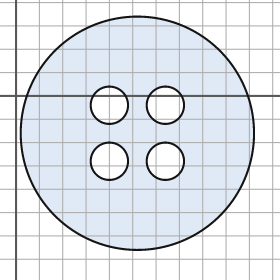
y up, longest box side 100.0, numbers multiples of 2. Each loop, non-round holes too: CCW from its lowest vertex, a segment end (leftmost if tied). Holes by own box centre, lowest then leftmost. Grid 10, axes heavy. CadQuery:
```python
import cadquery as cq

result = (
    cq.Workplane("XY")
    .moveTo(52.0, -16.0)
    .circle(50.0)
    .moveTo(40.0, -28.0)
    .circle(8.0)
    .moveTo(64.0, -28.0)
    .circle(8.0)
    .moveTo(40.0, -4.0)
    .circle(8.0)
    .moveTo(64.0, -4.0)
    .circle(8.0)
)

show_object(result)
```